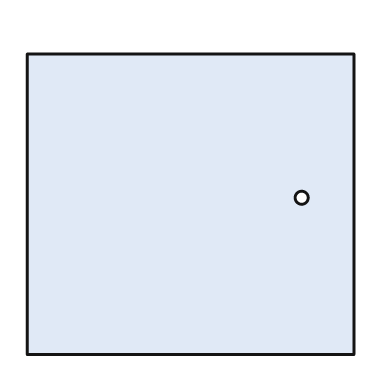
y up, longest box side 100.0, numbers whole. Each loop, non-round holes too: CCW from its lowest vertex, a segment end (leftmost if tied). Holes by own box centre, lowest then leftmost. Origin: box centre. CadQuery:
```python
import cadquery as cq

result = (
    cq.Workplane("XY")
    .moveTo(-50.0, -46.0)
    .lineTo(50.0, -46.0)
    .lineTo(50.0, 46.0)
    .lineTo(-50.0, 46.0)
    .close()
    .moveTo(34.0, 2.0)
    .circle(2.0)
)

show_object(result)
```